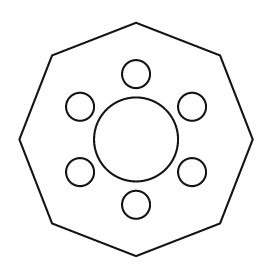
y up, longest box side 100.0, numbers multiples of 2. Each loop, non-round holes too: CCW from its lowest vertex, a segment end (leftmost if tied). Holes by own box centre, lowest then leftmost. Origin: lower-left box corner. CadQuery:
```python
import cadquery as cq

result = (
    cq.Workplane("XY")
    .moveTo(50.0, 0.0)
    .lineTo(86.0, 14.0)
    .lineTo(100.0, 50.0)
    .lineTo(86.0, 86.0)
    .lineTo(50.0, 100.0)
    .lineTo(14.0, 86.0)
    .lineTo(0.0, 50.0)
    .lineTo(14.0, 14.0)
    .close()
    .moveTo(50.0, 22.0)
    .circle(6.0)
    .moveTo(26.0, 36.0)
    .circle(6.0)
    .moveTo(74.0, 36.0)
    .circle(6.0)
    .moveTo(50.0, 50.0)
    .circle(18.0)
    .moveTo(26.0, 64.0)
    .circle(6.0)
    .moveTo(74.0, 64.0)
    .circle(6.0)
    .moveTo(50.0, 78.0)
    .circle(6.0)
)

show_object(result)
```